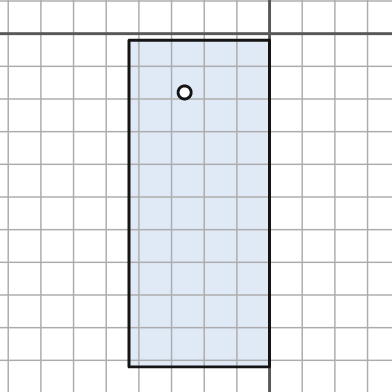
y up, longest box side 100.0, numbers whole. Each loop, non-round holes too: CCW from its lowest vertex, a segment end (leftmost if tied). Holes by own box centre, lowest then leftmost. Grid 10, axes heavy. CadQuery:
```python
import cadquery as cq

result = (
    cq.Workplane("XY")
    .moveTo(-43.0, -102.0)
    .lineTo(0.0, -102.0)
    .lineTo(0.0, -2.0)
    .lineTo(-43.0, -2.0)
    .close()
    .moveTo(-26.0, -18.0)
    .circle(2.0)
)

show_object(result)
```